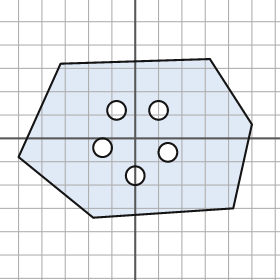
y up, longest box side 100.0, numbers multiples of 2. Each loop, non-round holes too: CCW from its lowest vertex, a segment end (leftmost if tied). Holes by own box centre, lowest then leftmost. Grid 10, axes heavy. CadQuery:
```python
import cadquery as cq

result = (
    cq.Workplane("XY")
    .moveTo(-18.0, -34.0)
    .lineTo(42.0, -30.0)
    .lineTo(50.0, 6.0)
    .lineTo(32.0, 34.0)
    .lineTo(-32.0, 32.0)
    .lineTo(-50.0, -8.0)
    .close()
    .moveTo(0.0, -16.0)
    .circle(4.0)
    .moveTo(14.0, -6.0)
    .circle(4.0)
    .moveTo(-14.0, -4.0)
    .circle(4.0)
    .moveTo(-8.0, 12.0)
    .circle(4.0)
    .moveTo(10.0, 12.0)
    .circle(4.0)
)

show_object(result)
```